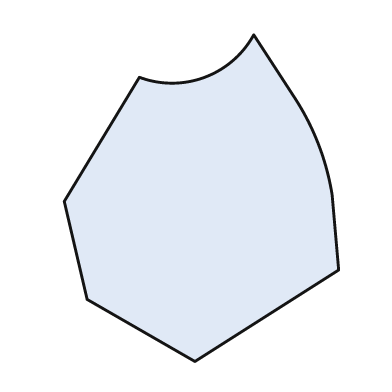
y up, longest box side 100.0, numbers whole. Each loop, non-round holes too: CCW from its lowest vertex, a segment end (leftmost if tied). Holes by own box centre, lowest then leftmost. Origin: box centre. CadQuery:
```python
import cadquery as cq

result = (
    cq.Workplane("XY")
    .moveTo(-2.0, -50.0)
    .lineTo(42.0, -22.0)
    .lineTo(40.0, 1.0)
    .threePointArc((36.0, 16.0), (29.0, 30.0))
    .lineTo(16.0, 50.0)
    .threePointArc((1.0, 37.0), (-19.0, 37.0))
    .lineTo(-42.0, -1.0)
    .lineTo(-35.0, -31.0)
    .close()
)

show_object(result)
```